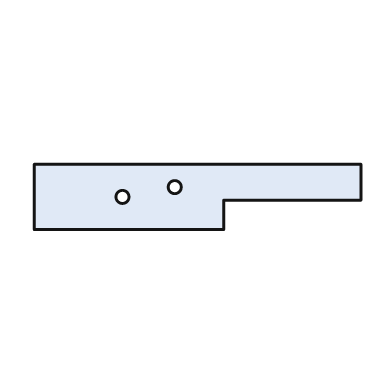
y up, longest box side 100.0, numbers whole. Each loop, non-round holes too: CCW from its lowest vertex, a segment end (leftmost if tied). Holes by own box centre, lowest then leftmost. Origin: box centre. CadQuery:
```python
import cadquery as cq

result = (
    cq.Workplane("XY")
    .moveTo(-50.0, -10.0)
    .lineTo(8.0, -10.0)
    .lineTo(8.0, -1.0)
    .lineTo(50.0, -1.0)
    .lineTo(50.0, 10.0)
    .lineTo(-50.0, 10.0)
    .close()
    .moveTo(-23.0, 0.0)
    .circle(2.0)
    .moveTo(-7.0, 3.0)
    .circle(2.0)
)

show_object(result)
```